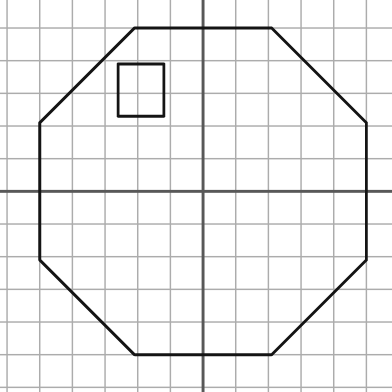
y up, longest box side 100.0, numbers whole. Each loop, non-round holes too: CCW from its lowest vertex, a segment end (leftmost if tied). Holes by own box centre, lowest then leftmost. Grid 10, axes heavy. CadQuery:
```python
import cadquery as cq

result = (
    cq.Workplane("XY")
    .moveTo(-21.0, -50.0)
    .lineTo(21.0, -50.0)
    .lineTo(50.0, -21.0)
    .lineTo(50.0, 21.0)
    .lineTo(21.0, 50.0)
    .lineTo(-21.0, 50.0)
    .lineTo(-50.0, 21.0)
    .lineTo(-50.0, -21.0)
    .close()
    .moveTo(-26.0, 23.0)
    .lineTo(-12.0, 23.0)
    .lineTo(-12.0, 39.0)
    .lineTo(-26.0, 39.0)
    .close()
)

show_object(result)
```